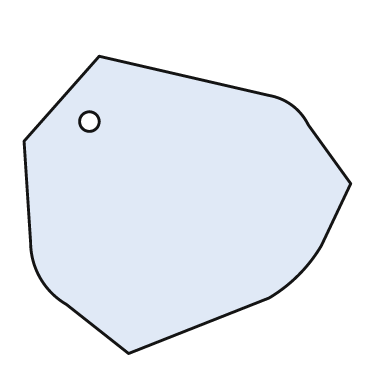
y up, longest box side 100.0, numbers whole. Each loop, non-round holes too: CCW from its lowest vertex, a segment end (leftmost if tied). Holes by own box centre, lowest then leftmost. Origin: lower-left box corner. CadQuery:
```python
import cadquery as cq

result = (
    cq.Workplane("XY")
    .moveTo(32.0, 0.0)
    .lineTo(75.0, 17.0)
    .threePointArc((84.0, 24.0), (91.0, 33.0))
    .lineTo(100.0, 52.0)
    .lineTo(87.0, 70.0)
    .threePointArc((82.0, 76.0), (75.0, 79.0))
    .lineTo(23.0, 91.0)
    .lineTo(0.0, 65.0)
    .lineTo(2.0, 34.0)
    .threePointArc((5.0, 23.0), (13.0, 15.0))
    .close()
    .moveTo(20.0, 71.0)
    .circle(3.0)
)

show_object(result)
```